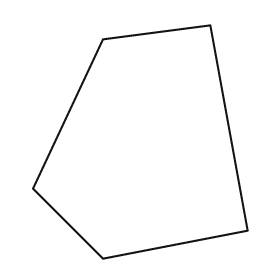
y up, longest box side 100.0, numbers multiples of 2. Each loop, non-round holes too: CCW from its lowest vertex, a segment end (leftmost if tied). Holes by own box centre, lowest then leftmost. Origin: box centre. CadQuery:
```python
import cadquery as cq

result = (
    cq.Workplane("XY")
    .moveTo(-16.0, -50.0)
    .lineTo(46.0, -38.0)
    .lineTo(30.0, 50.0)
    .lineTo(-16.0, 44.0)
    .lineTo(-46.0, -20.0)
    .close()
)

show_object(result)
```